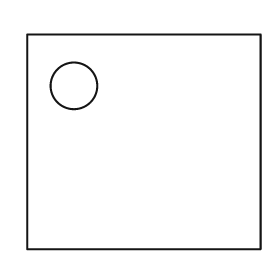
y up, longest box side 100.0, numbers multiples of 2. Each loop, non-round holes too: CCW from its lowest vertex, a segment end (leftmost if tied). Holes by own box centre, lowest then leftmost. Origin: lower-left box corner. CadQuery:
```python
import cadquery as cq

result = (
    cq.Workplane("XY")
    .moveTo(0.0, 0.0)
    .lineTo(100.0, 0.0)
    .lineTo(100.0, 92.0)
    .lineTo(0.0, 92.0)
    .close()
    .moveTo(20.0, 70.0)
    .circle(10.0)
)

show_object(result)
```